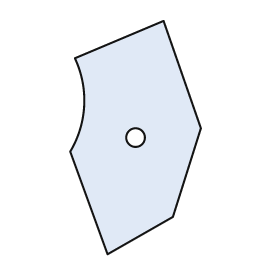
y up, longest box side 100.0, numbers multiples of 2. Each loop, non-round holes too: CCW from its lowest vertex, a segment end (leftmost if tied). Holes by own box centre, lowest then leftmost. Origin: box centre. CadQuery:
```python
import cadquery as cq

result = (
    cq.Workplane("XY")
    .moveTo(-12.0, -50.0)
    .lineTo(16.0, -34.0)
    .lineTo(28.0, 4.0)
    .lineTo(12.0, 50.0)
    .lineTo(-26.0, 34.0)
    .threePointArc((-22.0, 14.0), (-28.0, -6.0))
    .close()
    .moveTo(0.0, 0.0)
    .circle(4.0)
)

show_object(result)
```